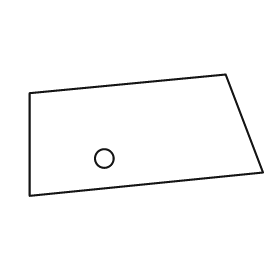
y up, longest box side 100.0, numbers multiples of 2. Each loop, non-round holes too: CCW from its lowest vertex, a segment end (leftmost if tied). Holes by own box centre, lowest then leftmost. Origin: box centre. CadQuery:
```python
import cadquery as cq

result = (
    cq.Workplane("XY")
    .moveTo(-50.0, -26.0)
    .lineTo(50.0, -16.0)
    .lineTo(34.0, 26.0)
    .lineTo(-50.0, 18.0)
    .close()
    .moveTo(-18.0, -10.0)
    .circle(4.0)
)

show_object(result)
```